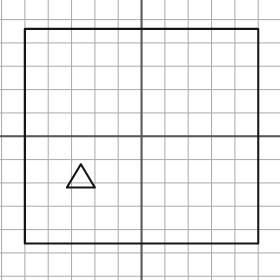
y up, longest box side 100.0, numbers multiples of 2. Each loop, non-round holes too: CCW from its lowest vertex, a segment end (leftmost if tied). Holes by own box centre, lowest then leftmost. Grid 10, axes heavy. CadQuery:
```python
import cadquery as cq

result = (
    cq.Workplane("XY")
    .moveTo(-50.0, -46.0)
    .lineTo(50.0, -46.0)
    .lineTo(50.0, 46.0)
    .lineTo(-50.0, 46.0)
    .close()
    .moveTo(-32.0, -22.0)
    .lineTo(-20.0, -22.0)
    .lineTo(-26.0, -12.0)
    .close()
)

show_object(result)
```